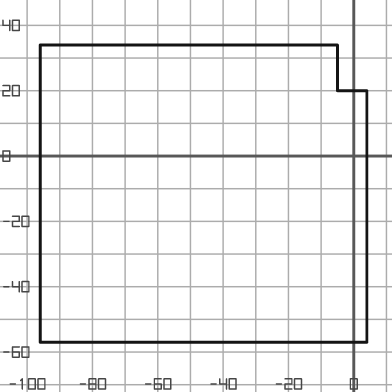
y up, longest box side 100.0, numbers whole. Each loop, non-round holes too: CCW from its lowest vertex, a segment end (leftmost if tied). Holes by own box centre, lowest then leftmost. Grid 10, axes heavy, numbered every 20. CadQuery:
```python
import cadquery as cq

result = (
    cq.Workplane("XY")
    .moveTo(-96.0, -57.0)
    .lineTo(4.0, -57.0)
    .lineTo(4.0, 20.0)
    .lineTo(-5.0, 20.0)
    .lineTo(-5.0, 34.0)
    .lineTo(-96.0, 34.0)
    .close()
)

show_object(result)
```